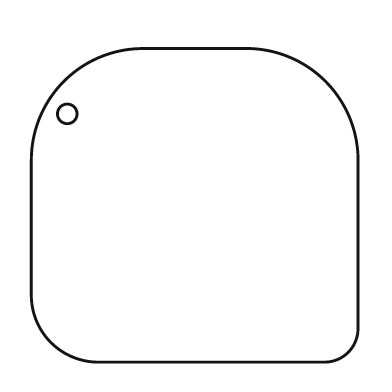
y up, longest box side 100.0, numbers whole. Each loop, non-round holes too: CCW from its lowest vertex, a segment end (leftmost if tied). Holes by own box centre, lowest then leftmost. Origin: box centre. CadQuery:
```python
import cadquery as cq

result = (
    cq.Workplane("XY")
    .moveTo(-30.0, -48.0)
    .lineTo(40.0, -48.0)
    .threePointArc((47.0, -45.0), (50.0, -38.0))
    .lineTo(50.0, 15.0)
    .threePointArc((40.0, 38.0), (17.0, 48.0))
    .lineTo(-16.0, 48.0)
    .threePointArc((-40.0, 38.0), (-50.0, 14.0))
    .lineTo(-50.0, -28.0)
    .threePointArc((-44.0, -42.0), (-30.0, -48.0))
    .close()
    .moveTo(-39.0, 28.0)
    .circle(3.0)
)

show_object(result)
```